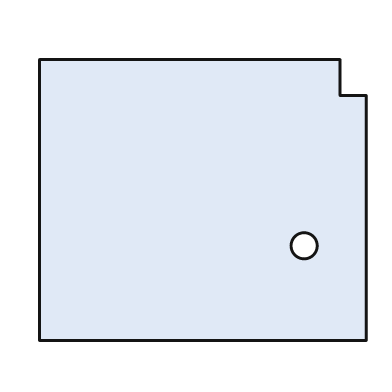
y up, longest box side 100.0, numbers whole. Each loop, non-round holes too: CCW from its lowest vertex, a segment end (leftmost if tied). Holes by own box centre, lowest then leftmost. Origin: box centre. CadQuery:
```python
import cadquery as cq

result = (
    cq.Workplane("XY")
    .moveTo(-50.0, -43.0)
    .lineTo(50.0, -43.0)
    .lineTo(50.0, 32.0)
    .lineTo(42.0, 32.0)
    .lineTo(42.0, 43.0)
    .lineTo(-50.0, 43.0)
    .close()
    .moveTo(31.0, -14.0)
    .circle(4.0)
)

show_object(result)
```